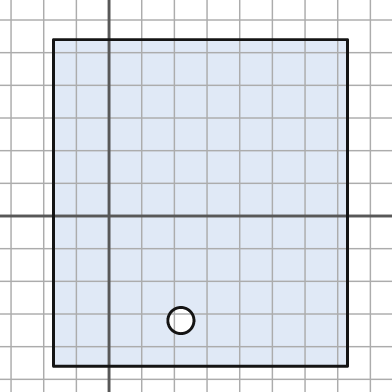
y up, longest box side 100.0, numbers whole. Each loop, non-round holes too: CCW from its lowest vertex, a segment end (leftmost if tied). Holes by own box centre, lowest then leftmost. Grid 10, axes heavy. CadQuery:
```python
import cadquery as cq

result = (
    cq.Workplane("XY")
    .moveTo(-17.0, -46.0)
    .lineTo(73.0, -46.0)
    .lineTo(73.0, 54.0)
    .lineTo(-17.0, 54.0)
    .close()
    .moveTo(22.0, -32.0)
    .circle(4.0)
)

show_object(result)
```